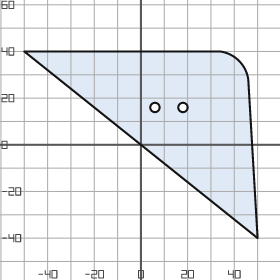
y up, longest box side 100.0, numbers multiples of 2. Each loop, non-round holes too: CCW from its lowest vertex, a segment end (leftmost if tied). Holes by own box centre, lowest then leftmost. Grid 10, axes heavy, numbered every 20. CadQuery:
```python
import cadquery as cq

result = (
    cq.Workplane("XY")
    .moveTo(50.0, -40.0)
    .lineTo(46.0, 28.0)
    .threePointArc((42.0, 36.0), (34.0, 40.0))
    .lineTo(-50.0, 40.0)
    .close()
    .moveTo(6.0, 16.0)
    .circle(2.0)
    .moveTo(18.0, 16.0)
    .circle(2.0)
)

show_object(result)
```